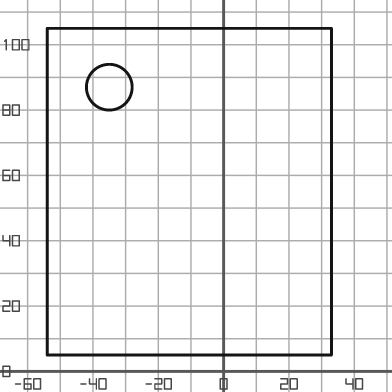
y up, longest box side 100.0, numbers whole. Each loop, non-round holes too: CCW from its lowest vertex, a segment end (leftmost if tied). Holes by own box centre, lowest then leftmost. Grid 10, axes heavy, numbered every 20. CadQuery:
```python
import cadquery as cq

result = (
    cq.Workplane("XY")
    .moveTo(-54.0, 5.0)
    .lineTo(33.0, 5.0)
    .lineTo(33.0, 105.0)
    .lineTo(-54.0, 105.0)
    .close()
    .moveTo(-35.0, 87.0)
    .circle(7.0)
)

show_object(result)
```